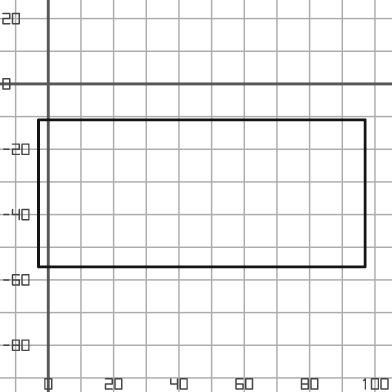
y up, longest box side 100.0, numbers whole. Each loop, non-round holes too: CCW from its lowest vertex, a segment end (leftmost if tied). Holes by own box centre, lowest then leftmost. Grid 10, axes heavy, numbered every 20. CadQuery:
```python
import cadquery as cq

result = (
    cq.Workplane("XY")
    .moveTo(-3.0, -56.0)
    .lineTo(97.0, -56.0)
    .lineTo(97.0, -11.0)
    .lineTo(-3.0, -11.0)
    .close()
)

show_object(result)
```